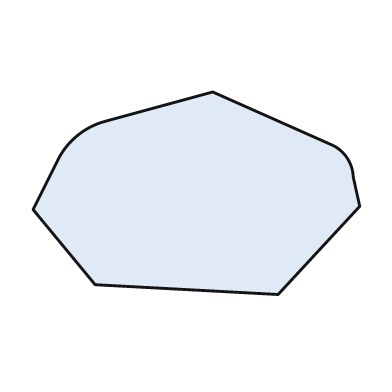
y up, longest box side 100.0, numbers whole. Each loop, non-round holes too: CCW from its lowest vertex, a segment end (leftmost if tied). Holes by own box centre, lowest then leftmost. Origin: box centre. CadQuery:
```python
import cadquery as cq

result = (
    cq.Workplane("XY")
    .moveTo(25.0, -31.0)
    .lineTo(50.0, -4.0)
    .lineTo(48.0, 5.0)
    .threePointArc((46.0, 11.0), (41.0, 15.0))
    .lineTo(5.0, 31.0)
    .lineTo(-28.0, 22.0)
    .threePointArc((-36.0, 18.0), (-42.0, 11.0))
    .lineTo(-50.0, -5.0)
    .lineTo(-31.0, -28.0)
    .close()
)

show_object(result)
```